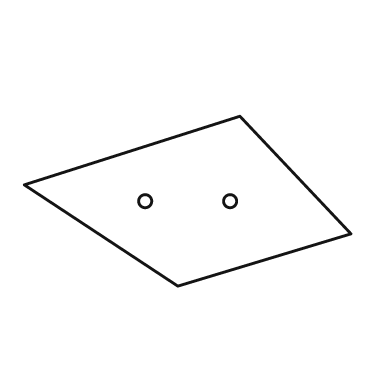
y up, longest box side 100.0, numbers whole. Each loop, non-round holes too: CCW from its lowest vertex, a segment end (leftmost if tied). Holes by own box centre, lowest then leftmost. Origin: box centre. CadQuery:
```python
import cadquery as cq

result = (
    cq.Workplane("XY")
    .moveTo(-3.0, -26.0)
    .lineTo(50.0, -10.0)
    .lineTo(16.0, 26.0)
    .lineTo(-50.0, 5.0)
    .close()
    .moveTo(-13.0, 0.0)
    .circle(2.0)
    .moveTo(13.0, 0.0)
    .circle(2.0)
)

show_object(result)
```